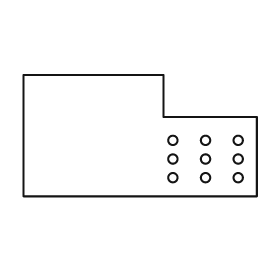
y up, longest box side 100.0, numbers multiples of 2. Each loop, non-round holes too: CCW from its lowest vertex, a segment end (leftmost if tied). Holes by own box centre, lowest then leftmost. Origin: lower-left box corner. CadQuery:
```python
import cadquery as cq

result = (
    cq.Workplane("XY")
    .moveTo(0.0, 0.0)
    .lineTo(100.0, 0.0)
    .lineTo(100.0, 34.0)
    .lineTo(60.0, 34.0)
    .lineTo(60.0, 52.0)
    .lineTo(0.0, 52.0)
    .close()
    .moveTo(64.0, 8.0)
    .circle(2.0)
    .moveTo(78.0, 8.0)
    .circle(2.0)
    .moveTo(92.0, 8.0)
    .circle(2.0)
    .moveTo(64.0, 16.0)
    .circle(2.0)
    .moveTo(78.0, 16.0)
    .circle(2.0)
    .moveTo(92.0, 16.0)
    .circle(2.0)
    .moveTo(64.0, 24.0)
    .circle(2.0)
    .moveTo(78.0, 24.0)
    .circle(2.0)
    .moveTo(92.0, 24.0)
    .circle(2.0)
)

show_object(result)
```